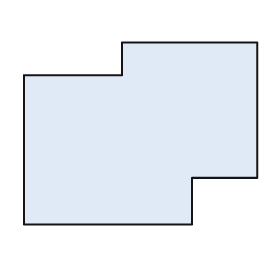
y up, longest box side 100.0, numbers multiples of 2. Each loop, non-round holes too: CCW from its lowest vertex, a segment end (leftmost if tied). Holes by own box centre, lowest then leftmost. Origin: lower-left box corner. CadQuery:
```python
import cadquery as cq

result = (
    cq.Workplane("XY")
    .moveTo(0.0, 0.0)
    .lineTo(72.0, 0.0)
    .lineTo(72.0, 20.0)
    .lineTo(100.0, 20.0)
    .lineTo(100.0, 78.0)
    .lineTo(42.0, 78.0)
    .lineTo(42.0, 64.0)
    .lineTo(0.0, 64.0)
    .close()
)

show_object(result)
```